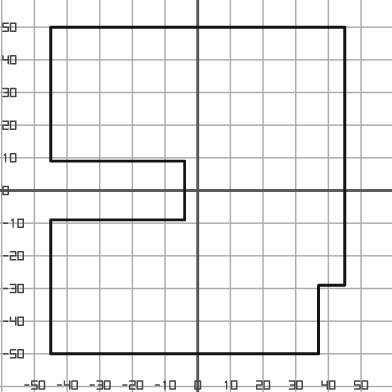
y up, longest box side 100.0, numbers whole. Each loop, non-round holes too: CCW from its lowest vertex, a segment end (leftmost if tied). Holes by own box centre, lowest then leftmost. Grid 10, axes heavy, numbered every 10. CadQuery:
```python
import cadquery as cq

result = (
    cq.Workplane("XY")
    .moveTo(-45.0, -50.0)
    .lineTo(37.0, -50.0)
    .lineTo(37.0, -29.0)
    .lineTo(45.0, -29.0)
    .lineTo(45.0, 50.0)
    .lineTo(-45.0, 50.0)
    .lineTo(-45.0, 9.0)
    .lineTo(-4.0, 9.0)
    .lineTo(-4.0, -9.0)
    .lineTo(-45.0, -9.0)
    .close()
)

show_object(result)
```